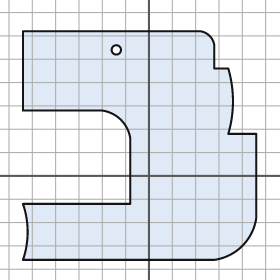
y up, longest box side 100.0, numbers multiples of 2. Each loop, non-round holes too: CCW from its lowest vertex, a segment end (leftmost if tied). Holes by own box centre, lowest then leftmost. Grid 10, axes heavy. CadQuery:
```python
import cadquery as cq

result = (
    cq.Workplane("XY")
    .moveTo(-54.0, -36.0)
    .lineTo(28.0, -36.0)
    .threePointArc((40.0, -30.0), (46.0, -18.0))
    .lineTo(46.0, 18.0)
    .lineTo(34.0, 18.0)
    .threePointArc((36.0, 32.0), (34.0, 46.0))
    .lineTo(28.0, 46.0)
    .lineTo(28.0, 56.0)
    .threePointArc((26.0, 60.0), (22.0, 62.0))
    .lineTo(-54.0, 62.0)
    .lineTo(-54.0, 28.0)
    .lineTo(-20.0, 28.0)
    .threePointArc((-12.0, 24.0), (-8.0, 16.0))
    .lineTo(-8.0, -12.0)
    .lineTo(-54.0, -12.0)
    .threePointArc((-52.0, -24.0), (-54.0, -36.0))
    .close()
    .moveTo(-14.0, 54.0)
    .circle(2.0)
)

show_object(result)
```